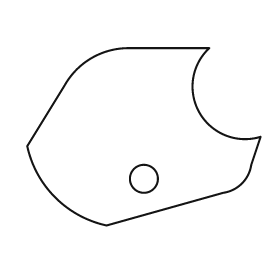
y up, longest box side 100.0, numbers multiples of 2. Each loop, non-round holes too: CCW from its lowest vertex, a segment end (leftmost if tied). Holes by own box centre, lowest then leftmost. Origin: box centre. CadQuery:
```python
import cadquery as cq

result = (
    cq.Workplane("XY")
    .moveTo(-16.0, -38.0)
    .lineTo(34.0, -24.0)
    .threePointArc((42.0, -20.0), (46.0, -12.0))
    .lineTo(50.0, 0.0)
    .threePointArc((24.0, 10.0), (28.0, 38.0))
    .lineTo(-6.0, 38.0)
    .threePointArc((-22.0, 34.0), (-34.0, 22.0))
    .lineTo(-50.0, -4.0)
    .threePointArc((-38.0, -26.0), (-16.0, -38.0))
    .close()
    .moveTo(0.0, -18.0)
    .circle(6.0)
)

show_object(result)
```